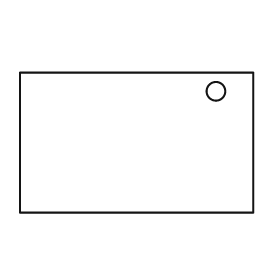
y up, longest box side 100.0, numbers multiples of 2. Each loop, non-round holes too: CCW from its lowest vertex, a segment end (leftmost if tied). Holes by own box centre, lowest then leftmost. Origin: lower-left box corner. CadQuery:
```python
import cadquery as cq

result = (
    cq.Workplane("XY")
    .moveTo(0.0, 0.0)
    .lineTo(100.0, 0.0)
    .lineTo(100.0, 60.0)
    .lineTo(0.0, 60.0)
    .close()
    .moveTo(84.0, 52.0)
    .circle(4.0)
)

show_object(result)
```